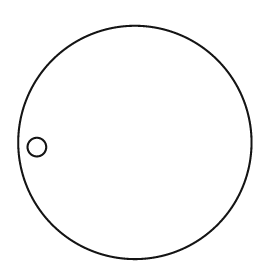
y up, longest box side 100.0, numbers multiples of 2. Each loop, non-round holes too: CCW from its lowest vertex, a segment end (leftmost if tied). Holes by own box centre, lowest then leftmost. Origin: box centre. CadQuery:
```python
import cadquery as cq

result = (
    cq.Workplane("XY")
    .moveTo(0.0, 0.0)
    .circle(50.0)
    .moveTo(-42.0, -2.0)
    .circle(4.0)
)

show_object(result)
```